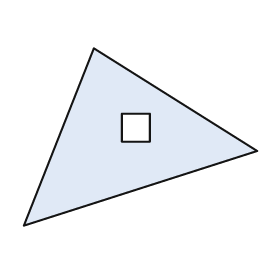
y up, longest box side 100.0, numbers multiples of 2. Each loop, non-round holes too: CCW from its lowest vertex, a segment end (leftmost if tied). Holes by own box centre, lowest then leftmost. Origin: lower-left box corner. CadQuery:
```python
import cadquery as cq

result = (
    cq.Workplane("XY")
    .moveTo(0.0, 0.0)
    .lineTo(100.0, 32.0)
    .lineTo(30.0, 76.0)
    .close()
    .moveTo(42.0, 36.0)
    .lineTo(54.0, 36.0)
    .lineTo(54.0, 48.0)
    .lineTo(42.0, 48.0)
    .close()
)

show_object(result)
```